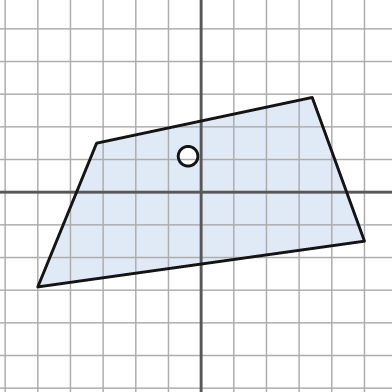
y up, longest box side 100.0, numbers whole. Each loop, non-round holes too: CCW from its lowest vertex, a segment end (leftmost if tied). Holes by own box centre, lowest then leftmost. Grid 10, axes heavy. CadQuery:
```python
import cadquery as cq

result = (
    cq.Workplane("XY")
    .moveTo(-50.0, -29.0)
    .lineTo(50.0, -15.0)
    .lineTo(34.0, 29.0)
    .lineTo(-32.0, 15.0)
    .close()
    .moveTo(-4.0, 11.0)
    .circle(3.0)
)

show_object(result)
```